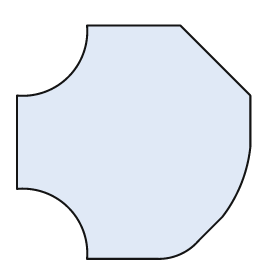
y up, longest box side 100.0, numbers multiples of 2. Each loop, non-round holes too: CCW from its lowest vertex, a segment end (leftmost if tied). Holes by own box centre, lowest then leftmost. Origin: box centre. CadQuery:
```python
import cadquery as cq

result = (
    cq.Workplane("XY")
    .moveTo(-20.0, -50.0)
    .lineTo(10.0, -50.0)
    .threePointArc((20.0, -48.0), (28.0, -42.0))
    .lineTo(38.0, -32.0)
    .threePointArc((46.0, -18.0), (50.0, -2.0))
    .lineTo(50.0, 20.0)
    .lineTo(20.0, 50.0)
    .lineTo(-20.0, 50.0)
    .threePointArc((-28.0, 28.0), (-50.0, 20.0))
    .lineTo(-50.0, -20.0)
    .threePointArc((-28.0, -28.0), (-20.0, -50.0))
    .close()
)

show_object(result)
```